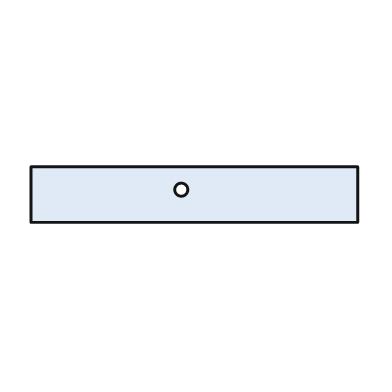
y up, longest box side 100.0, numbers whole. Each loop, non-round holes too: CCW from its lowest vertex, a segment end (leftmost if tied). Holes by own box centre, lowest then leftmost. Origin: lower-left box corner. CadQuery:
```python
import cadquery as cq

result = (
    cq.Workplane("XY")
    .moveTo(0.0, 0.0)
    .lineTo(100.0, 0.0)
    .lineTo(100.0, 17.0)
    .lineTo(0.0, 17.0)
    .close()
    .moveTo(46.0, 10.0)
    .circle(2.0)
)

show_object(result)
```